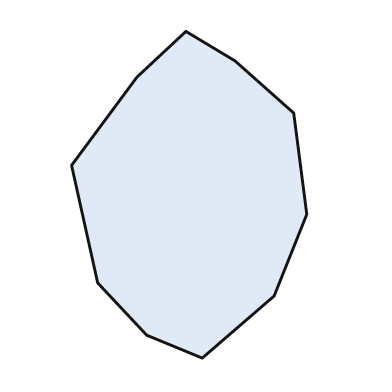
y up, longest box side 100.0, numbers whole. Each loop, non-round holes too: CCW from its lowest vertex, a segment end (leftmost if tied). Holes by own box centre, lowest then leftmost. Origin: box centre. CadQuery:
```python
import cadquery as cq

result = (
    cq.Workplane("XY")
    .moveTo(4.0, -50.0)
    .lineTo(26.0, -31.0)
    .lineTo(36.0, -6.0)
    .lineTo(32.0, 25.0)
    .lineTo(14.0, 41.0)
    .lineTo(-1.0, 50.0)
    .lineTo(-16.0, 36.0)
    .lineTo(-36.0, 9.0)
    .lineTo(-28.0, -27.0)
    .lineTo(-13.0, -43.0)
    .close()
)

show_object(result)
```